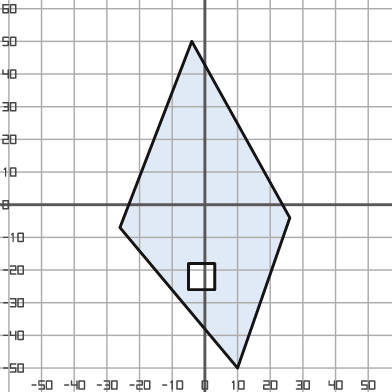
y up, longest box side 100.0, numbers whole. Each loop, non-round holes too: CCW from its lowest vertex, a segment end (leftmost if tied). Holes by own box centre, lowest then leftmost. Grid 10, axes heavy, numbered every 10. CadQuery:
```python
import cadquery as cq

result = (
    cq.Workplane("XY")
    .moveTo(10.0, -50.0)
    .lineTo(26.0, -4.0)
    .lineTo(-4.0, 50.0)
    .lineTo(-26.0, -7.0)
    .close()
    .moveTo(-5.0, -26.0)
    .lineTo(3.0, -26.0)
    .lineTo(3.0, -18.0)
    .lineTo(-5.0, -18.0)
    .close()
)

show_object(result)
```